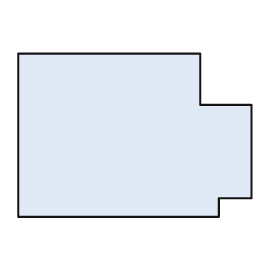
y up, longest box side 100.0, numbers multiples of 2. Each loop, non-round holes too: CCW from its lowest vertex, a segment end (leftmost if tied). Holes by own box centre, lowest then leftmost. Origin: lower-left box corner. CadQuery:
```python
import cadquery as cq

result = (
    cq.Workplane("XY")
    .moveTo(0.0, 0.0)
    .lineTo(86.0, 0.0)
    .lineTo(86.0, 8.0)
    .lineTo(100.0, 8.0)
    .lineTo(100.0, 48.0)
    .lineTo(78.0, 48.0)
    .lineTo(78.0, 70.0)
    .lineTo(0.0, 70.0)
    .close()
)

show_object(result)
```